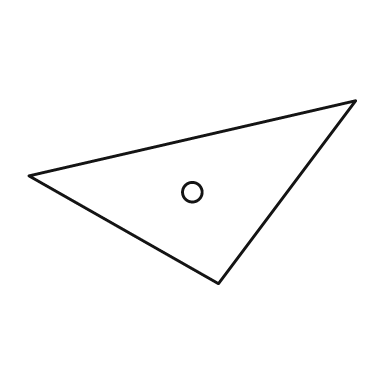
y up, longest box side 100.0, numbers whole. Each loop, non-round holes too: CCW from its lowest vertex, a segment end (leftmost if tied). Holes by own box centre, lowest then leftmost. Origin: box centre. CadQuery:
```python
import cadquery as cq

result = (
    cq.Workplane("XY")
    .moveTo(8.0, -28.0)
    .lineTo(50.0, 28.0)
    .lineTo(-50.0, 5.0)
    .close()
    .moveTo(0.0, 0.0)
    .circle(3.0)
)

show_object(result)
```